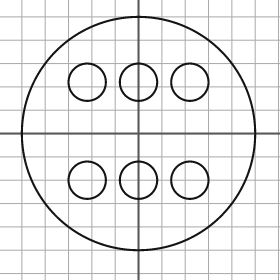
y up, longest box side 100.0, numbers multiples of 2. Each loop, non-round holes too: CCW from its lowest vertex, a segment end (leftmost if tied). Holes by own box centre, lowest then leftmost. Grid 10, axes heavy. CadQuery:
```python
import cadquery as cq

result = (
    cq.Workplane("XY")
    .moveTo(0.0, 0.0)
    .circle(50.0)
    .moveTo(-22.0, -20.0)
    .circle(8.0)
    .moveTo(0.0, -20.0)
    .circle(8.0)
    .moveTo(22.0, -20.0)
    .circle(8.0)
    .moveTo(-22.0, 22.0)
    .circle(8.0)
    .moveTo(0.0, 22.0)
    .circle(8.0)
    .moveTo(22.0, 22.0)
    .circle(8.0)
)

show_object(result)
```